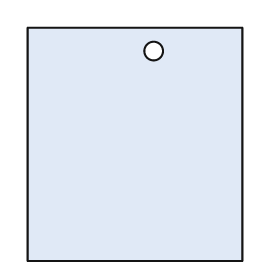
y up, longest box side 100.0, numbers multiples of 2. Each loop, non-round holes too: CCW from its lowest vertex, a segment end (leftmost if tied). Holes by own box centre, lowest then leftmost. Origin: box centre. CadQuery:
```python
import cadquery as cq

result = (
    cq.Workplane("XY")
    .moveTo(-46.0, -50.0)
    .lineTo(46.0, -50.0)
    .lineTo(46.0, 50.0)
    .lineTo(-46.0, 50.0)
    .close()
    .moveTo(8.0, 40.0)
    .circle(4.0)
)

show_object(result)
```